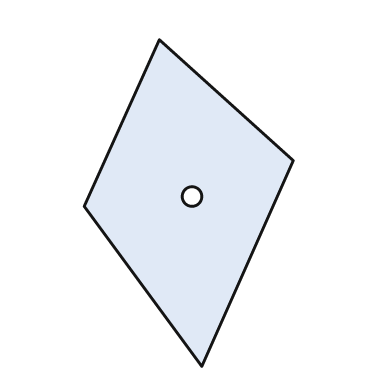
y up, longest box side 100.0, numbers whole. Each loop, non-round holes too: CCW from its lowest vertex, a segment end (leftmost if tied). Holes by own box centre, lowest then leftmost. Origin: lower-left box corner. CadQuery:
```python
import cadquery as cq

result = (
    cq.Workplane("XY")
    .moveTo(36.0, 0.0)
    .lineTo(64.0, 63.0)
    .lineTo(23.0, 100.0)
    .lineTo(0.0, 49.0)
    .close()
    .moveTo(33.0, 52.0)
    .circle(3.0)
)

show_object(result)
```